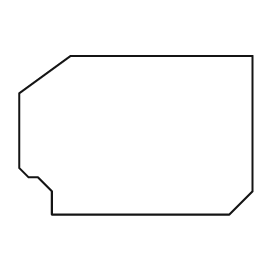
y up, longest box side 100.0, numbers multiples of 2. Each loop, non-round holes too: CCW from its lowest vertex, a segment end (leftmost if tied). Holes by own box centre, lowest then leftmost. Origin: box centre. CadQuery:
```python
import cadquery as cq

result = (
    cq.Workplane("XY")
    .moveTo(-36.0, -34.0)
    .lineTo(40.0, -34.0)
    .lineTo(50.0, -24.0)
    .lineTo(50.0, 34.0)
    .lineTo(-28.0, 34.0)
    .lineTo(-50.0, 18.0)
    .lineTo(-50.0, -14.0)
    .lineTo(-46.0, -18.0)
    .lineTo(-42.0, -18.0)
    .lineTo(-36.0, -24.0)
    .close()
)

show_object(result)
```